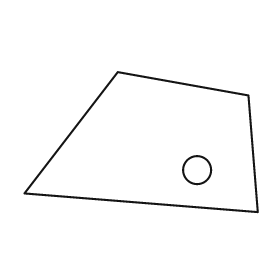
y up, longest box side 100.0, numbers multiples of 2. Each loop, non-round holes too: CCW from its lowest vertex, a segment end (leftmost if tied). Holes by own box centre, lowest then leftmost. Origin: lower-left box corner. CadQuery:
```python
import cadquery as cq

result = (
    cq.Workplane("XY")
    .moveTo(100.0, 0.0)
    .lineTo(96.0, 50.0)
    .lineTo(40.0, 60.0)
    .lineTo(0.0, 8.0)
    .close()
    .moveTo(74.0, 18.0)
    .circle(6.0)
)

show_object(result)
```